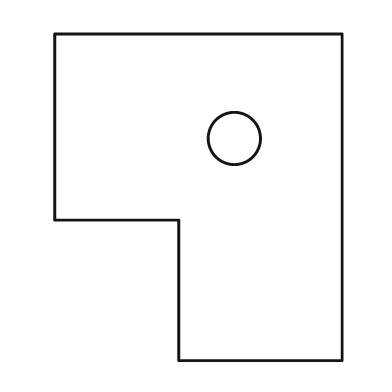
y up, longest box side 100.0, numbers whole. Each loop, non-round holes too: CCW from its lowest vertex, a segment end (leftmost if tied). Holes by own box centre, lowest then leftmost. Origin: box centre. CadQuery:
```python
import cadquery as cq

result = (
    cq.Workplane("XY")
    .moveTo(-6.0, -50.0)
    .lineTo(44.0, -50.0)
    .lineTo(44.0, 50.0)
    .lineTo(-44.0, 50.0)
    .lineTo(-44.0, -7.0)
    .lineTo(-6.0, -7.0)
    .close()
    .moveTo(11.0, 18.0)
    .circle(8.0)
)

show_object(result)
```